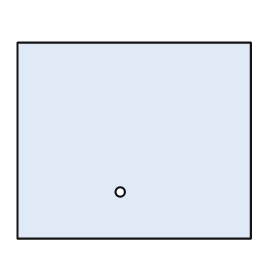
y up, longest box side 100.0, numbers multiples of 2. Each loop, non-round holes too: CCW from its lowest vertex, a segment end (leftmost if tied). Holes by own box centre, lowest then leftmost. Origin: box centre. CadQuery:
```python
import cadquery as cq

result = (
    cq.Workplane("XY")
    .moveTo(-50.0, -42.0)
    .lineTo(50.0, -42.0)
    .lineTo(50.0, 42.0)
    .lineTo(-50.0, 42.0)
    .close()
    .moveTo(-6.0, -22.0)
    .circle(2.0)
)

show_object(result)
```